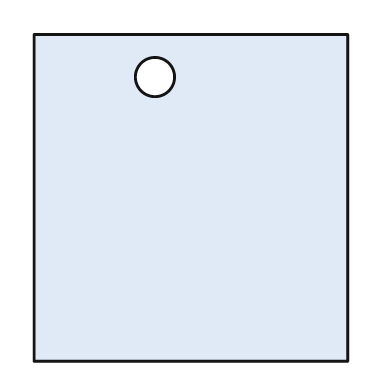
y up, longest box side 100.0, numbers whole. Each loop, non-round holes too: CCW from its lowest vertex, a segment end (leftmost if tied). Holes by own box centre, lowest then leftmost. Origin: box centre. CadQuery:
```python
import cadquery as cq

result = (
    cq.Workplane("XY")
    .moveTo(-48.0, -50.0)
    .lineTo(48.0, -50.0)
    .lineTo(48.0, 50.0)
    .lineTo(-48.0, 50.0)
    .close()
    .moveTo(-11.0, 37.0)
    .circle(6.0)
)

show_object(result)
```